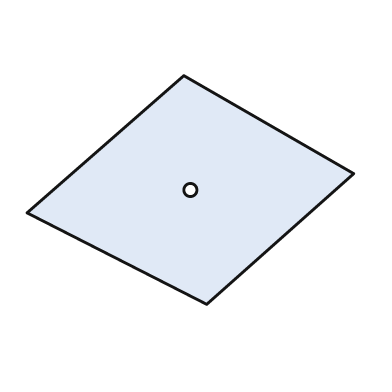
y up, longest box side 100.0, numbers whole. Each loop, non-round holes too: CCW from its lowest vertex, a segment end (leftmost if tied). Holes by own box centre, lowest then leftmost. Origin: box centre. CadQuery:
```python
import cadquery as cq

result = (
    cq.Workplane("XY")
    .moveTo(5.0, -35.0)
    .lineTo(50.0, 5.0)
    .lineTo(-2.0, 35.0)
    .lineTo(-50.0, -7.0)
    .close()
    .moveTo(0.0, 0.0)
    .circle(2.0)
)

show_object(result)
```